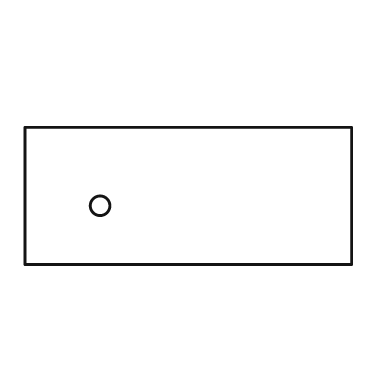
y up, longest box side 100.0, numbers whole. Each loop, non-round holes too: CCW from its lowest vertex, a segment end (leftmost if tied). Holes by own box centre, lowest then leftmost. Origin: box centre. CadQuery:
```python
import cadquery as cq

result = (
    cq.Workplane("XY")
    .moveTo(-50.0, -21.0)
    .lineTo(50.0, -21.0)
    .lineTo(50.0, 21.0)
    .lineTo(-50.0, 21.0)
    .close()
    .moveTo(-27.0, -3.0)
    .circle(3.0)
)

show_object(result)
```